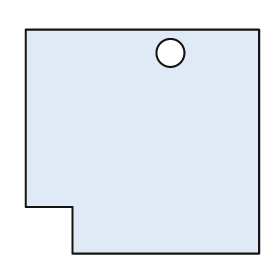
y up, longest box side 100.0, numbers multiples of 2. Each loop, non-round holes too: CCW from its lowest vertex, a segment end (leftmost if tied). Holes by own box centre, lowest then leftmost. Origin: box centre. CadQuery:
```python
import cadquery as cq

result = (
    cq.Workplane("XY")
    .moveTo(-30.0, -48.0)
    .lineTo(50.0, -48.0)
    .lineTo(50.0, 48.0)
    .lineTo(-50.0, 48.0)
    .lineTo(-50.0, -28.0)
    .lineTo(-30.0, -28.0)
    .close()
    .moveTo(12.0, 38.0)
    .circle(6.0)
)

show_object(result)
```